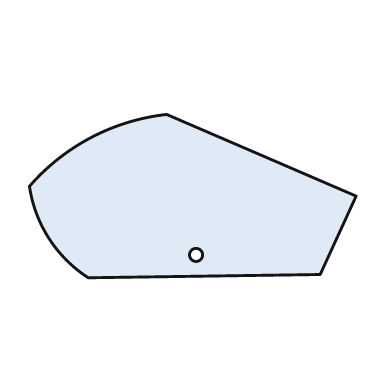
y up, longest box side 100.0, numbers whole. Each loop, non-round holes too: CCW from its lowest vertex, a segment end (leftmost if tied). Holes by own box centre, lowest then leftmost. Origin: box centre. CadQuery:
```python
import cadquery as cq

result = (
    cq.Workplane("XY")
    .moveTo(-32.0, -25.0)
    .lineTo(39.0, -24.0)
    .lineTo(50.0, 0.0)
    .lineTo(-8.0, 25.0)
    .threePointArc((-31.0, 18.0), (-50.0, 3.0))
    .threePointArc((-44.0, -13.0), (-32.0, -25.0))
    .close()
    .moveTo(1.0, -18.0)
    .circle(2.0)
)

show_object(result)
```